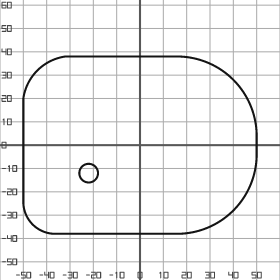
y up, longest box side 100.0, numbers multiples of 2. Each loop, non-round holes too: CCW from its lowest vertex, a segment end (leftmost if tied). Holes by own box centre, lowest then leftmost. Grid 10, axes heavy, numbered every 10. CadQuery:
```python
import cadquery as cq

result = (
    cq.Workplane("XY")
    .moveTo(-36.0, -38.0)
    .lineTo(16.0, -38.0)
    .threePointArc((40.0, -28.0), (50.0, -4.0))
    .lineTo(50.0, 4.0)
    .threePointArc((40.0, 28.0), (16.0, 38.0))
    .lineTo(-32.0, 38.0)
    .threePointArc((-44.0, 32.0), (-50.0, 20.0))
    .lineTo(-50.0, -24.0)
    .threePointArc((-46.0, -34.0), (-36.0, -38.0))
    .close()
    .moveTo(-22.0, -12.0)
    .circle(4.0)
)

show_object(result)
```